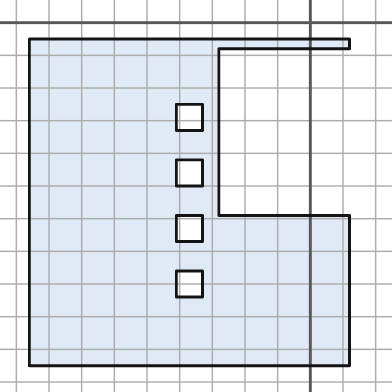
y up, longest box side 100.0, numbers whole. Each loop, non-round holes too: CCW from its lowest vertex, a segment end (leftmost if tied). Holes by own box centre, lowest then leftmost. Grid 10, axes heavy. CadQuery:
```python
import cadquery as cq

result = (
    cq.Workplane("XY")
    .moveTo(-86.0, -105.0)
    .lineTo(12.0, -105.0)
    .lineTo(12.0, -59.0)
    .lineTo(-28.0, -59.0)
    .lineTo(-28.0, -8.0)
    .lineTo(12.0, -8.0)
    .lineTo(12.0, -5.0)
    .lineTo(-86.0, -5.0)
    .close()
    .moveTo(-41.0, -84.0)
    .lineTo(-33.0, -84.0)
    .lineTo(-33.0, -76.0)
    .lineTo(-41.0, -76.0)
    .close()
    .moveTo(-41.0, -67.0)
    .lineTo(-33.0, -67.0)
    .lineTo(-33.0, -59.0)
    .lineTo(-41.0, -59.0)
    .close()
    .moveTo(-41.0, -50.0)
    .lineTo(-33.0, -50.0)
    .lineTo(-33.0, -42.0)
    .lineTo(-41.0, -42.0)
    .close()
    .moveTo(-41.0, -33.0)
    .lineTo(-33.0, -33.0)
    .lineTo(-33.0, -25.0)
    .lineTo(-41.0, -25.0)
    .close()
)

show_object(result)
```